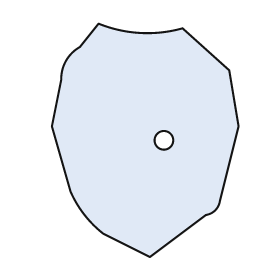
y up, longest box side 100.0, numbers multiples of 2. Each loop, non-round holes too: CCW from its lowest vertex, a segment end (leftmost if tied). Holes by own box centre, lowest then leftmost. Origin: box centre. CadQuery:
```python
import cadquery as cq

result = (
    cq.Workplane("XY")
    .moveTo(2.0, -50.0)
    .lineTo(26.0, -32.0)
    .threePointArc((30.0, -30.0), (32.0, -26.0))
    .lineTo(40.0, 6.0)
    .lineTo(36.0, 30.0)
    .lineTo(16.0, 48.0)
    .threePointArc((-2.0, 46.0), (-20.0, 50.0))
    .lineTo(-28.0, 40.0)
    .threePointArc((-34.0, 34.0), (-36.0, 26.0))
    .lineTo(-40.0, 6.0)
    .lineTo(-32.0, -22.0)
    .threePointArc((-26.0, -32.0), (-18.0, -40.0))
    .close()
    .moveTo(8.0, 0.0)
    .circle(4.0)
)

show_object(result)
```